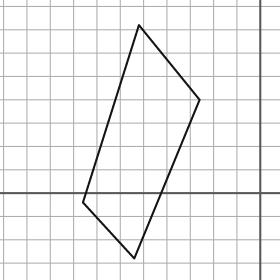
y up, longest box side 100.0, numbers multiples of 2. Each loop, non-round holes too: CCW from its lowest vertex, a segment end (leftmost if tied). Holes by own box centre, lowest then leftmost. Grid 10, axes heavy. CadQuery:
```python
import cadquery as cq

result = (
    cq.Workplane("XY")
    .moveTo(-54.0, -28.0)
    .lineTo(-26.0, 40.0)
    .lineTo(-52.0, 72.0)
    .lineTo(-76.0, -4.0)
    .close()
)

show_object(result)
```